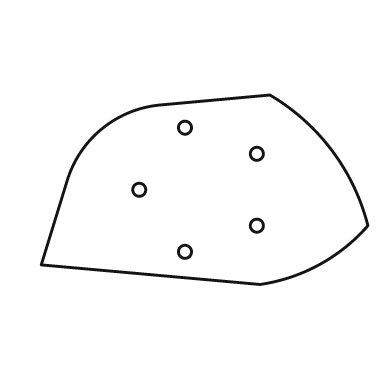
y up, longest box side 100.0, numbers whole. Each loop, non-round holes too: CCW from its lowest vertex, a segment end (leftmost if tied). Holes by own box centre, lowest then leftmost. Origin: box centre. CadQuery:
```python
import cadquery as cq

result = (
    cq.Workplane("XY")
    .moveTo(17.0, -29.0)
    .threePointArc((35.0, -23.0), (50.0, -11.0))
    .threePointArc((39.0, 12.0), (20.0, 29.0))
    .lineTo(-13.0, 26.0)
    .threePointArc((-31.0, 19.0), (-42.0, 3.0))
    .lineTo(-50.0, -23.0)
    .close()
    .moveTo(-6.0, -19.0)
    .circle(2.0)
    .moveTo(16.0, -11.0)
    .circle(2.0)
    .moveTo(-20.0, 0.0)
    .circle(2.0)
    .moveTo(16.0, 11.0)
    .circle(2.0)
    .moveTo(-6.0, 19.0)
    .circle(2.0)
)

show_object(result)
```